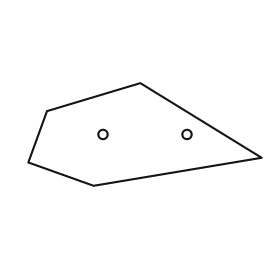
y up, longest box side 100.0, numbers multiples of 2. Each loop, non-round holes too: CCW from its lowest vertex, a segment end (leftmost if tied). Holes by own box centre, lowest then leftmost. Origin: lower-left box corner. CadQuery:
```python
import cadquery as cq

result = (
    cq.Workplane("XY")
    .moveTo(28.0, 0.0)
    .lineTo(100.0, 12.0)
    .lineTo(48.0, 44.0)
    .lineTo(8.0, 32.0)
    .lineTo(0.0, 10.0)
    .close()
    .moveTo(32.0, 22.0)
    .circle(2.0)
    .moveTo(68.0, 22.0)
    .circle(2.0)
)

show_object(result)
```